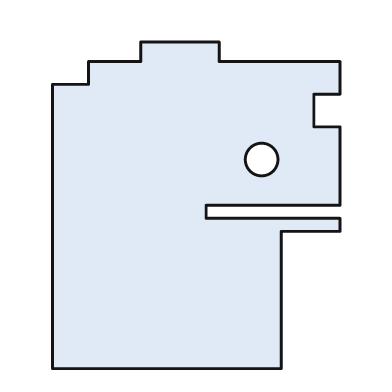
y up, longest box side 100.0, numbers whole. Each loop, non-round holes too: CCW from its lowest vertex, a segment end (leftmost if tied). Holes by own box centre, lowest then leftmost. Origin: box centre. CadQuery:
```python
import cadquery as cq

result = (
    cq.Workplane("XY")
    .moveTo(-44.0, -50.0)
    .lineTo(26.0, -50.0)
    .lineTo(26.0, -8.0)
    .lineTo(44.0, -8.0)
    .lineTo(44.0, -4.0)
    .lineTo(3.0, -4.0)
    .lineTo(3.0, 0.0)
    .lineTo(44.0, 0.0)
    .lineTo(44.0, 24.0)
    .lineTo(36.0, 24.0)
    .lineTo(36.0, 34.0)
    .lineTo(44.0, 34.0)
    .lineTo(44.0, 44.0)
    .lineTo(7.0, 44.0)
    .lineTo(7.0, 50.0)
    .lineTo(-17.0, 50.0)
    .lineTo(-17.0, 44.0)
    .lineTo(-33.0, 44.0)
    .lineTo(-33.0, 37.0)
    .lineTo(-44.0, 37.0)
    .close()
    .moveTo(20.0, 14.0)
    .circle(5.0)
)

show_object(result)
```